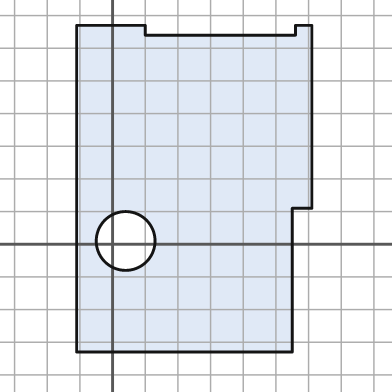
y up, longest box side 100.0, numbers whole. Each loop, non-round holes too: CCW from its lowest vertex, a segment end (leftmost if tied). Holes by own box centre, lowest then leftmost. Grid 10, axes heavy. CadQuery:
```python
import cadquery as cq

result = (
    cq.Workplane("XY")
    .moveTo(-11.0, -33.0)
    .lineTo(55.0, -33.0)
    .lineTo(55.0, 11.0)
    .lineTo(61.0, 11.0)
    .lineTo(61.0, 67.0)
    .lineTo(56.0, 67.0)
    .lineTo(56.0, 64.0)
    .lineTo(10.0, 64.0)
    .lineTo(10.0, 67.0)
    .lineTo(-11.0, 67.0)
    .close()
    .moveTo(4.0, 1.0)
    .circle(9.0)
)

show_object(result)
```